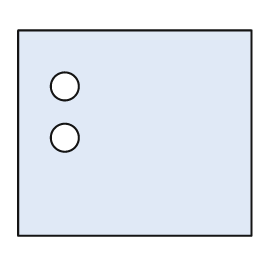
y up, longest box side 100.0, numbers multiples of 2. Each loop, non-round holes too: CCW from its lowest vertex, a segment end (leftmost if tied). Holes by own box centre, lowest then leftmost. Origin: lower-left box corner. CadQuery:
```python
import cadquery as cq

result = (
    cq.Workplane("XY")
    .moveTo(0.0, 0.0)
    .lineTo(100.0, 0.0)
    .lineTo(100.0, 88.0)
    .lineTo(0.0, 88.0)
    .close()
    .moveTo(20.0, 42.0)
    .circle(6.0)
    .moveTo(20.0, 64.0)
    .circle(6.0)
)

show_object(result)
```